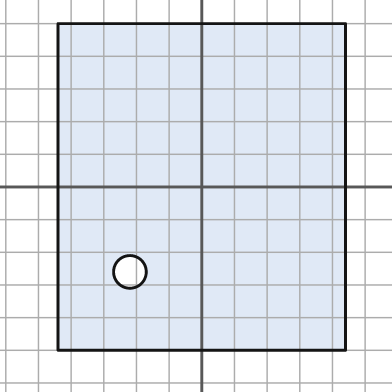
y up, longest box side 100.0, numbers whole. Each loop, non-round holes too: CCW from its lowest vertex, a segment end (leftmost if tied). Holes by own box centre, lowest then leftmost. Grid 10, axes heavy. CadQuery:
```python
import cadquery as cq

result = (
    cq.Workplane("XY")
    .moveTo(-44.0, -50.0)
    .lineTo(44.0, -50.0)
    .lineTo(44.0, 50.0)
    .lineTo(-44.0, 50.0)
    .close()
    .moveTo(-22.0, -26.0)
    .circle(5.0)
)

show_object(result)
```